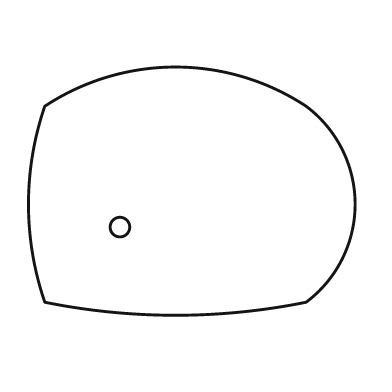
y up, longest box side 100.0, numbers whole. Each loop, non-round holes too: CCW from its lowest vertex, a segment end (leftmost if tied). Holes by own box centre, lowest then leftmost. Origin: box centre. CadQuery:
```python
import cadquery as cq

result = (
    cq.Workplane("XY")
    .moveTo(-45.0, -34.0)
    .threePointArc((-5.0, -38.0), (35.0, -34.0))
    .threePointArc((50.0, -4.0), (35.0, 26.0))
    .threePointArc((-5.0, 38.0), (-45.0, 26.0))
    .threePointArc((-50.0, -4.0), (-45.0, -34.0))
    .close()
    .moveTo(-22.0, -11.0)
    .circle(3.0)
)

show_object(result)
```